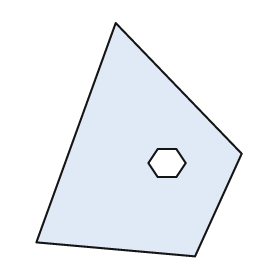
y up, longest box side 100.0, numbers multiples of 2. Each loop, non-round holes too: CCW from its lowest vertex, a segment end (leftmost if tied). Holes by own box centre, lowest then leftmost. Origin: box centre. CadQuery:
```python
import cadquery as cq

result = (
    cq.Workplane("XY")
    .moveTo(24.0, -50.0)
    .lineTo(44.0, -6.0)
    .lineTo(-10.0, 50.0)
    .lineTo(-44.0, -44.0)
    .close()
    .moveTo(8.0, -16.0)
    .lineTo(16.0, -16.0)
    .lineTo(20.0, -10.0)
    .lineTo(16.0, -4.0)
    .lineTo(8.0, -4.0)
    .lineTo(4.0, -10.0)
    .close()
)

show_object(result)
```